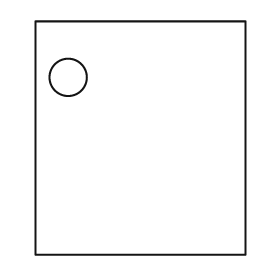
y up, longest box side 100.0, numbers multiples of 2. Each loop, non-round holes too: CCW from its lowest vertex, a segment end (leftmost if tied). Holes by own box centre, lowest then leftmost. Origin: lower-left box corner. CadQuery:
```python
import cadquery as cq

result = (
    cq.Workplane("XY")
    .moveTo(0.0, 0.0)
    .lineTo(90.0, 0.0)
    .lineTo(90.0, 100.0)
    .lineTo(0.0, 100.0)
    .close()
    .moveTo(14.0, 76.0)
    .circle(8.0)
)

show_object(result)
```